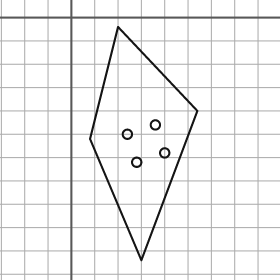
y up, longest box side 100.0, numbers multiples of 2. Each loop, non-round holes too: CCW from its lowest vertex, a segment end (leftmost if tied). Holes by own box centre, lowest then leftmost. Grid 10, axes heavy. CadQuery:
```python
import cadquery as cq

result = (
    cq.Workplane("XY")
    .moveTo(30.0, -104.0)
    .lineTo(54.0, -40.0)
    .lineTo(20.0, -4.0)
    .lineTo(8.0, -52.0)
    .close()
    .moveTo(28.0, -62.0)
    .circle(2.0)
    .moveTo(40.0, -58.0)
    .circle(2.0)
    .moveTo(24.0, -50.0)
    .circle(2.0)
    .moveTo(36.0, -46.0)
    .circle(2.0)
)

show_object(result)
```